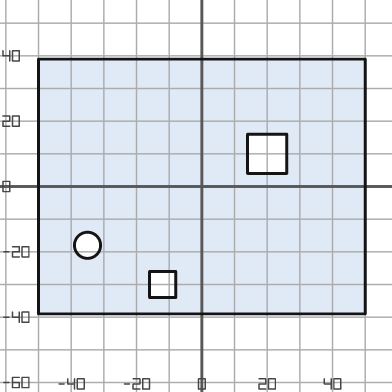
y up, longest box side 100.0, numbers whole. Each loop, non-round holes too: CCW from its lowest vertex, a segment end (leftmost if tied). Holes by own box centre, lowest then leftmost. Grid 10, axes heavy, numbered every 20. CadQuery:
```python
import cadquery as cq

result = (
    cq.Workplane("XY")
    .moveTo(-50.0, -39.0)
    .lineTo(50.0, -39.0)
    .lineTo(50.0, 39.0)
    .lineTo(-50.0, 39.0)
    .close()
    .moveTo(-16.0, -34.0)
    .lineTo(-8.0, -34.0)
    .lineTo(-8.0, -26.0)
    .lineTo(-16.0, -26.0)
    .close()
    .moveTo(-35.0, -18.0)
    .circle(4.0)
    .moveTo(14.0, 4.0)
    .lineTo(26.0, 4.0)
    .lineTo(26.0, 16.0)
    .lineTo(14.0, 16.0)
    .close()
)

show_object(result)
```